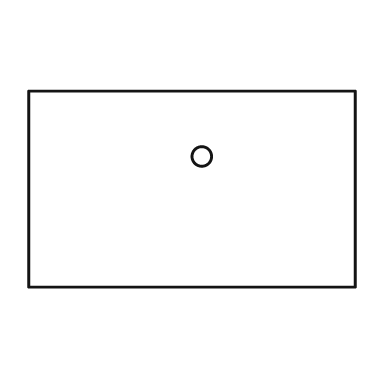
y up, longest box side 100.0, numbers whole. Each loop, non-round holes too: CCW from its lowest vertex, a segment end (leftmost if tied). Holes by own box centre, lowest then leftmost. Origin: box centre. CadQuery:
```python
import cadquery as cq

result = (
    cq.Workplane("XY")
    .moveTo(-50.0, -30.0)
    .lineTo(50.0, -30.0)
    .lineTo(50.0, 30.0)
    .lineTo(-50.0, 30.0)
    .close()
    .moveTo(3.0, 10.0)
    .circle(3.0)
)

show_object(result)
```